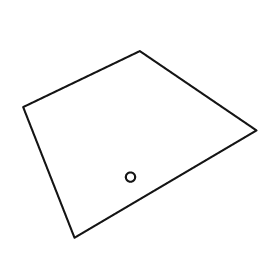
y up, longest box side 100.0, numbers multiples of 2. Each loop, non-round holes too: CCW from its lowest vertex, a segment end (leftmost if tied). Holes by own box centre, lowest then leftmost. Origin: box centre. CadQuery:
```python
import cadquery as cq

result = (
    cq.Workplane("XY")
    .moveTo(-28.0, -40.0)
    .lineTo(50.0, 6.0)
    .lineTo(0.0, 40.0)
    .lineTo(-50.0, 16.0)
    .close()
    .moveTo(-4.0, -14.0)
    .circle(2.0)
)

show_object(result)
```